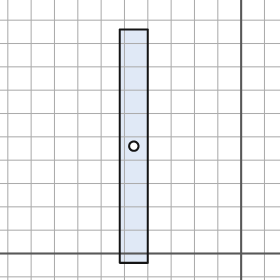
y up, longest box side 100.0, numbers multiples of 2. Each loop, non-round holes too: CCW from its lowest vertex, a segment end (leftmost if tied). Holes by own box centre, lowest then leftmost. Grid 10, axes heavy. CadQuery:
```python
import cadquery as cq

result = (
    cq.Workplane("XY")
    .moveTo(-52.0, -4.0)
    .lineTo(-40.0, -4.0)
    .lineTo(-40.0, 96.0)
    .lineTo(-52.0, 96.0)
    .close()
    .moveTo(-46.0, 46.0)
    .circle(2.0)
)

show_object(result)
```